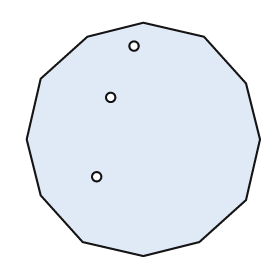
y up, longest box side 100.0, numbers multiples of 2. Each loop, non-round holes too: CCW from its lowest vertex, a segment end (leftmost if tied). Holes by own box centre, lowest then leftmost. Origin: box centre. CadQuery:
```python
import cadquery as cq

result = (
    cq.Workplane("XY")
    .moveTo(0.0, -50.0)
    .lineTo(24.0, -44.0)
    .lineTo(44.0, -26.0)
    .lineTo(50.0, 0.0)
    .lineTo(44.0, 24.0)
    .lineTo(26.0, 44.0)
    .lineTo(0.0, 50.0)
    .lineTo(-24.0, 44.0)
    .lineTo(-44.0, 26.0)
    .lineTo(-50.0, 0.0)
    .lineTo(-44.0, -24.0)
    .lineTo(-26.0, -44.0)
    .close()
    .moveTo(-20.0, -16.0)
    .circle(2.0)
    .moveTo(-14.0, 18.0)
    .circle(2.0)
    .moveTo(-4.0, 40.0)
    .circle(2.0)
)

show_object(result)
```